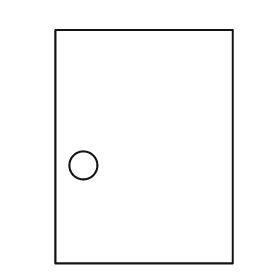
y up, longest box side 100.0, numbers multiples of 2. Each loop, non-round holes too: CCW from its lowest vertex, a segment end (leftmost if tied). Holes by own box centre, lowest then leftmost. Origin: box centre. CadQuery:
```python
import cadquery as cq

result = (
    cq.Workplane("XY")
    .moveTo(-38.0, -50.0)
    .lineTo(38.0, -50.0)
    .lineTo(38.0, 50.0)
    .lineTo(-38.0, 50.0)
    .close()
    .moveTo(-26.0, -8.0)
    .circle(6.0)
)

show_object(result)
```